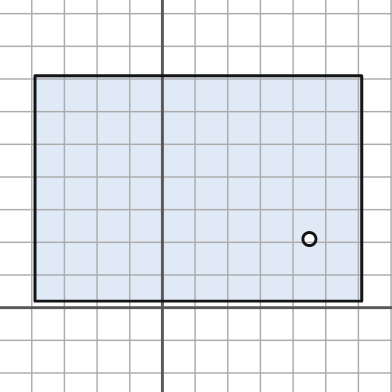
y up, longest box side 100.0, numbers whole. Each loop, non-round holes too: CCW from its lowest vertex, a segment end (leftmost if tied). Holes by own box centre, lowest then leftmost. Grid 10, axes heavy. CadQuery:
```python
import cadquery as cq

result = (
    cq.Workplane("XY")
    .moveTo(-39.0, 2.0)
    .lineTo(61.0, 2.0)
    .lineTo(61.0, 71.0)
    .lineTo(-39.0, 71.0)
    .close()
    .moveTo(45.0, 21.0)
    .circle(2.0)
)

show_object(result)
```